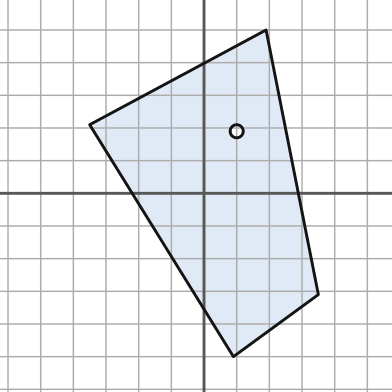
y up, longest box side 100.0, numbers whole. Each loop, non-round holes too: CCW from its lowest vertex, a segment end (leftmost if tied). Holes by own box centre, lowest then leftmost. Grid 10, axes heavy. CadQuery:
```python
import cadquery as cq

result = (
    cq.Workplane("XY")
    .moveTo(9.0, -50.0)
    .lineTo(35.0, -31.0)
    .lineTo(19.0, 50.0)
    .lineTo(-35.0, 21.0)
    .close()
    .moveTo(10.0, 19.0)
    .circle(2.0)
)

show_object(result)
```